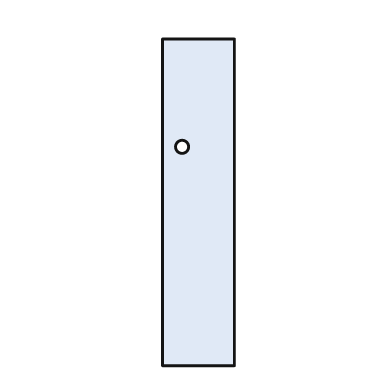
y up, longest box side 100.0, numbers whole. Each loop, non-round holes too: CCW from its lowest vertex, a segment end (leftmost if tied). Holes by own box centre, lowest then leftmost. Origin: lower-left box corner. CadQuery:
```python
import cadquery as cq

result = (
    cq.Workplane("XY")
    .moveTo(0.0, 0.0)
    .lineTo(22.0, 0.0)
    .lineTo(22.0, 100.0)
    .lineTo(0.0, 100.0)
    .close()
    .moveTo(6.0, 67.0)
    .circle(2.0)
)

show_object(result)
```